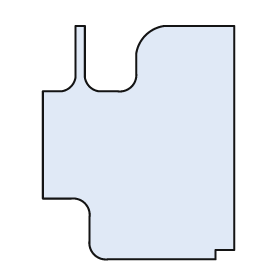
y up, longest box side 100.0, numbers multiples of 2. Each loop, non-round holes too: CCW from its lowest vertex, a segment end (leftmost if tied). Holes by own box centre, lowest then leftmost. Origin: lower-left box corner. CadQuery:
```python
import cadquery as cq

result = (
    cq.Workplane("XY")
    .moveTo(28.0, 0.0)
    .lineTo(74.0, 0.0)
    .lineTo(74.0, 4.0)
    .lineTo(82.0, 4.0)
    .lineTo(82.0, 100.0)
    .lineTo(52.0, 100.0)
    .threePointArc((44.0, 96.0), (40.0, 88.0))
    .lineTo(40.0, 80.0)
    .threePointArc((38.0, 74.0), (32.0, 72.0))
    .lineTo(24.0, 72.0)
    .threePointArc((20.0, 74.0), (18.0, 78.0))
    .lineTo(18.0, 100.0)
    .lineTo(14.0, 100.0)
    .lineTo(14.0, 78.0)
    .threePointArc((12.0, 74.0), (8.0, 72.0))
    .lineTo(0.0, 72.0)
    .lineTo(0.0, 26.0)
    .lineTo(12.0, 26.0)
    .threePointArc((18.0, 24.0), (20.0, 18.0))
    .lineTo(20.0, 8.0)
    .threePointArc((22.0, 2.0), (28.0, 0.0))
    .close()
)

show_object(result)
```